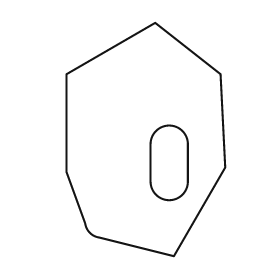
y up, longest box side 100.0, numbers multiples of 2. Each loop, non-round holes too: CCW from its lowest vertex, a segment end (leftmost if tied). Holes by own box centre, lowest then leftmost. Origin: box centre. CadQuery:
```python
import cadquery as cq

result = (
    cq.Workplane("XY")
    .moveTo(12.0, -50.0)
    .lineTo(34.0, -12.0)
    .lineTo(32.0, 28.0)
    .lineTo(4.0, 50.0)
    .lineTo(-34.0, 28.0)
    .lineTo(-34.0, -14.0)
    .lineTo(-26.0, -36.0)
    .threePointArc((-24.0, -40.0), (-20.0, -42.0))
    .close()
    .moveTo(2.0, -18.0)
    .threePointArc((10.0, -26.0), (18.0, -18.0))
    .lineTo(18.0, -2.0)
    .threePointArc((10.0, 6.0), (2.0, -2.0))
    .close()
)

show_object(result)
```